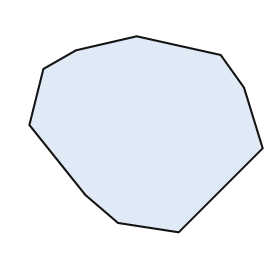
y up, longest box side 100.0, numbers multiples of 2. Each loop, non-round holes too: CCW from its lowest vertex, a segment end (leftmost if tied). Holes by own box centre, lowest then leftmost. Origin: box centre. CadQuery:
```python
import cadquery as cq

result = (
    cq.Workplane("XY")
    .moveTo(14.0, -42.0)
    .lineTo(50.0, -6.0)
    .lineTo(42.0, 20.0)
    .lineTo(32.0, 34.0)
    .lineTo(-4.0, 42.0)
    .lineTo(-30.0, 36.0)
    .lineTo(-44.0, 28.0)
    .lineTo(-50.0, 4.0)
    .lineTo(-26.0, -26.0)
    .lineTo(-12.0, -38.0)
    .close()
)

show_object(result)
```